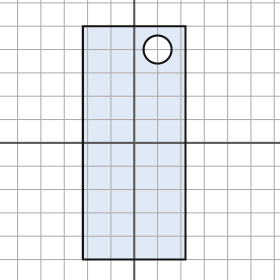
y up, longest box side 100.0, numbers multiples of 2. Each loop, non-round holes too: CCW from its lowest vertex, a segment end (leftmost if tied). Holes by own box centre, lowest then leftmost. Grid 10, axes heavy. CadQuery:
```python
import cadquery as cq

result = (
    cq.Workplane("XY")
    .moveTo(-22.0, -50.0)
    .lineTo(22.0, -50.0)
    .lineTo(22.0, 50.0)
    .lineTo(-22.0, 50.0)
    .close()
    .moveTo(10.0, 40.0)
    .circle(6.0)
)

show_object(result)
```